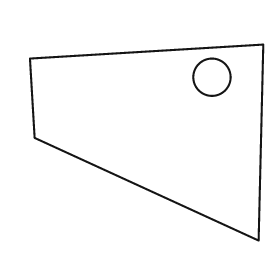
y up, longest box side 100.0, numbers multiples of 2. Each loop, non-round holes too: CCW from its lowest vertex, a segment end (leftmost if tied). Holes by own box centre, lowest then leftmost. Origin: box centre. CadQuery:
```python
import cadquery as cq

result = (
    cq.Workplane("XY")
    .moveTo(48.0, -42.0)
    .lineTo(50.0, 42.0)
    .lineTo(-50.0, 36.0)
    .lineTo(-48.0, 2.0)
    .close()
    .moveTo(28.0, 28.0)
    .circle(8.0)
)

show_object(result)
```